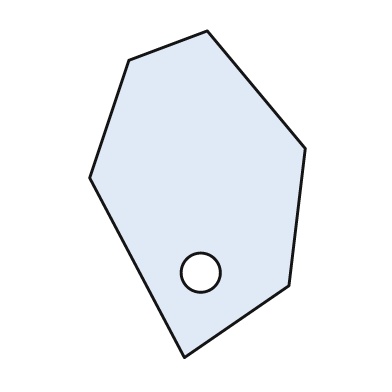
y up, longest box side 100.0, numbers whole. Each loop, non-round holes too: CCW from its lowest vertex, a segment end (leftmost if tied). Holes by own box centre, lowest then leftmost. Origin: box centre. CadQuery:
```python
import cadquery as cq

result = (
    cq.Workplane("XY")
    .moveTo(-4.0, -50.0)
    .lineTo(28.0, -28.0)
    .lineTo(33.0, 14.0)
    .lineTo(3.0, 50.0)
    .lineTo(-21.0, 41.0)
    .lineTo(-33.0, 5.0)
    .close()
    .moveTo(1.0, -24.0)
    .circle(6.0)
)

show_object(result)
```